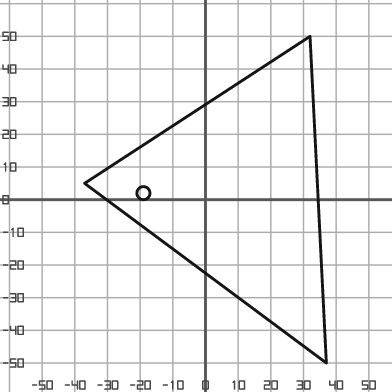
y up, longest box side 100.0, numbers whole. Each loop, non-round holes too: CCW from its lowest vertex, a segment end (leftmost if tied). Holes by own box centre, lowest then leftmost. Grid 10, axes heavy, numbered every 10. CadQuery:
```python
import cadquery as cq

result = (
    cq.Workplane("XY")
    .moveTo(37.0, -50.0)
    .lineTo(32.0, 50.0)
    .lineTo(-37.0, 5.0)
    .close()
    .moveTo(-19.0, 2.0)
    .circle(2.0)
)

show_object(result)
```